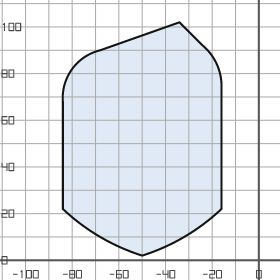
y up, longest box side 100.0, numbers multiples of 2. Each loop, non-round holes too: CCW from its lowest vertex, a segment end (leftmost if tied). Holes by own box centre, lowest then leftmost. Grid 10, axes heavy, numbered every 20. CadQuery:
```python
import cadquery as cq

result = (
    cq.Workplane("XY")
    .moveTo(-50.0, 2.0)
    .threePointArc((-32.0, 10.0), (-16.0, 22.0))
    .lineTo(-16.0, 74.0)
    .threePointArc((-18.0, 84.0), (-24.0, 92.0))
    .lineTo(-34.0, 102.0)
    .lineTo(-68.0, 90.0)
    .threePointArc((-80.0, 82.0), (-84.0, 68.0))
    .lineTo(-84.0, 22.0)
    .threePointArc((-68.0, 10.0), (-50.0, 2.0))
    .close()
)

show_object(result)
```